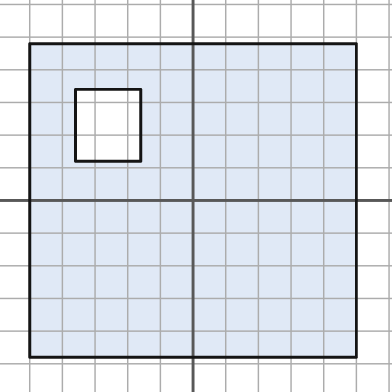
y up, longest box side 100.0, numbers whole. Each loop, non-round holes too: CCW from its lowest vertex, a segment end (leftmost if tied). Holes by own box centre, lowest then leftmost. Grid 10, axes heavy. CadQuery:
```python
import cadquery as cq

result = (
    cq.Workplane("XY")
    .moveTo(-50.0, -48.0)
    .lineTo(50.0, -48.0)
    .lineTo(50.0, 48.0)
    .lineTo(-50.0, 48.0)
    .close()
    .moveTo(-36.0, 12.0)
    .lineTo(-16.0, 12.0)
    .lineTo(-16.0, 34.0)
    .lineTo(-36.0, 34.0)
    .close()
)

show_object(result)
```